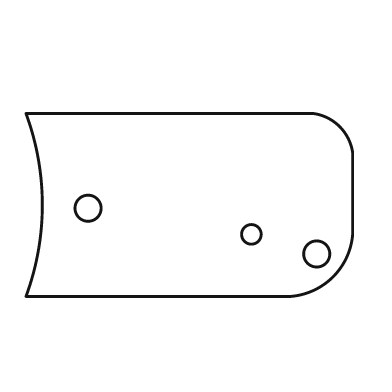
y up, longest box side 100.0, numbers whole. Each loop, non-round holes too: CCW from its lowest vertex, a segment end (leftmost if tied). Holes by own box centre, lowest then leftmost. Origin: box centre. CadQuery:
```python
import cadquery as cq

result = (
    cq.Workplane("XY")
    .moveTo(-50.0, -28.0)
    .lineTo(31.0, -28.0)
    .threePointArc((44.0, -22.0), (50.0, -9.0))
    .lineTo(50.0, 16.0)
    .threePointArc((46.0, 24.0), (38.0, 28.0))
    .lineTo(-50.0, 28.0)
    .threePointArc((-45.0, 0.0), (-50.0, -28.0))
    .close()
    .moveTo(39.0, -15.0)
    .circle(4.0)
    .moveTo(19.0, -9.0)
    .circle(3.0)
    .moveTo(-31.0, -1.0)
    .circle(4.0)
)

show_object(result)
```